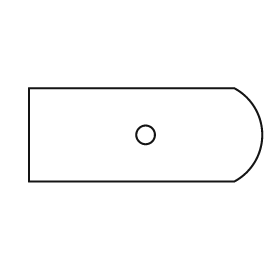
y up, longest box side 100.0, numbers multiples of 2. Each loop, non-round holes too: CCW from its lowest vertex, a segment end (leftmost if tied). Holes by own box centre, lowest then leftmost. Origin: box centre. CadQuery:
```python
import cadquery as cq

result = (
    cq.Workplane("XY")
    .moveTo(-50.0, -20.0)
    .lineTo(38.0, -20.0)
    .threePointArc((50.0, 0.0), (38.0, 20.0))
    .lineTo(-50.0, 20.0)
    .close()
    .moveTo(0.0, 0.0)
    .circle(4.0)
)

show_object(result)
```